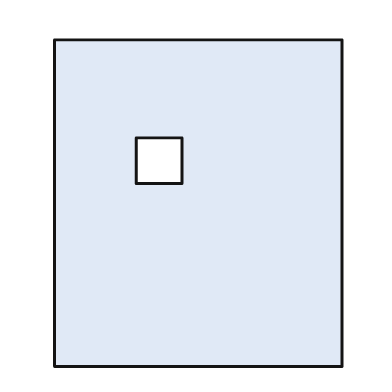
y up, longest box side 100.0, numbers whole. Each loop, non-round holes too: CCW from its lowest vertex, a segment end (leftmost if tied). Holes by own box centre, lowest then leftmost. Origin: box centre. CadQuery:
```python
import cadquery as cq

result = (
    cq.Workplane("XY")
    .moveTo(-44.0, -50.0)
    .lineTo(44.0, -50.0)
    .lineTo(44.0, 50.0)
    .lineTo(-44.0, 50.0)
    .close()
    .moveTo(-19.0, 6.0)
    .lineTo(-5.0, 6.0)
    .lineTo(-5.0, 20.0)
    .lineTo(-19.0, 20.0)
    .close()
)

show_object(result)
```